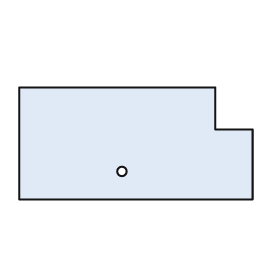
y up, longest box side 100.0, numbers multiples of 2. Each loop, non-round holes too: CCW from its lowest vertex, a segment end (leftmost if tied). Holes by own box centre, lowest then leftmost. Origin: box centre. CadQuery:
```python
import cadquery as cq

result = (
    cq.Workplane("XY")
    .moveTo(-50.0, -24.0)
    .lineTo(50.0, -24.0)
    .lineTo(50.0, 6.0)
    .lineTo(34.0, 6.0)
    .lineTo(34.0, 24.0)
    .lineTo(-50.0, 24.0)
    .close()
    .moveTo(-6.0, -12.0)
    .circle(2.0)
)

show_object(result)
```